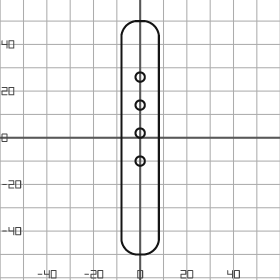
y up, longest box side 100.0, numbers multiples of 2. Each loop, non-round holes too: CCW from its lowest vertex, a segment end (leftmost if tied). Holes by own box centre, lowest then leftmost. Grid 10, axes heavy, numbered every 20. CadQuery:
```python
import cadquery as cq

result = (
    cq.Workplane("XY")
    .moveTo(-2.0, -50.0)
    .lineTo(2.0, -50.0)
    .threePointArc((6.0, -48.0), (8.0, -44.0))
    .lineTo(8.0, 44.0)
    .threePointArc((6.0, 48.0), (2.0, 50.0))
    .lineTo(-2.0, 50.0)
    .threePointArc((-6.0, 48.0), (-8.0, 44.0))
    .lineTo(-8.0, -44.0)
    .threePointArc((-6.0, -48.0), (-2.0, -50.0))
    .close()
    .moveTo(0.0, -10.0)
    .circle(2.0)
    .moveTo(0.0, 2.0)
    .circle(2.0)
    .moveTo(0.0, 14.0)
    .circle(2.0)
    .moveTo(0.0, 26.0)
    .circle(2.0)
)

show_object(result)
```